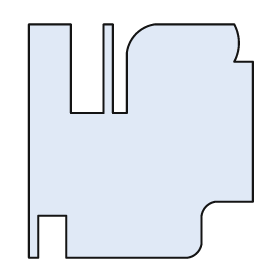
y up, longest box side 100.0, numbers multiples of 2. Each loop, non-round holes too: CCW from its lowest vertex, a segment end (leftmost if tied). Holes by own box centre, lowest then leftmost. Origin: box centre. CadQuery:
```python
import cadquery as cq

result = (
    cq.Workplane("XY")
    .moveTo(-48.0, -50.0)
    .lineTo(-44.0, -50.0)
    .lineTo(-44.0, -32.0)
    .lineTo(-32.0, -32.0)
    .lineTo(-32.0, -50.0)
    .lineTo(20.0, -50.0)
    .threePointArc((24.0, -48.0), (26.0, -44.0))
    .lineTo(26.0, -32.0)
    .threePointArc((28.0, -28.0), (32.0, -26.0))
    .lineTo(48.0, -26.0)
    .lineTo(48.0, 34.0)
    .lineTo(40.0, 34.0)
    .threePointArc((42.0, 42.0), (40.0, 50.0))
    .lineTo(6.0, 50.0)
    .threePointArc((-2.0, 46.0), (-6.0, 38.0))
    .lineTo(-6.0, 12.0)
    .lineTo(-12.0, 12.0)
    .lineTo(-12.0, 50.0)
    .lineTo(-16.0, 50.0)
    .lineTo(-16.0, 12.0)
    .lineTo(-30.0, 12.0)
    .lineTo(-30.0, 50.0)
    .lineTo(-48.0, 50.0)
    .close()
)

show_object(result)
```